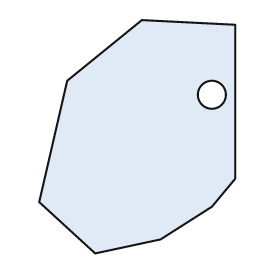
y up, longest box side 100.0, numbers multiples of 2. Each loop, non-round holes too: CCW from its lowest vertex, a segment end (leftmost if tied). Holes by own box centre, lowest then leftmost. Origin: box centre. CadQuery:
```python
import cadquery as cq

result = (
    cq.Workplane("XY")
    .moveTo(-18.0, -50.0)
    .lineTo(10.0, -44.0)
    .lineTo(32.0, -30.0)
    .lineTo(42.0, -18.0)
    .lineTo(42.0, 48.0)
    .lineTo(2.0, 50.0)
    .lineTo(-30.0, 24.0)
    .lineTo(-42.0, -28.0)
    .close()
    .moveTo(32.0, 18.0)
    .circle(6.0)
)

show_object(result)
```